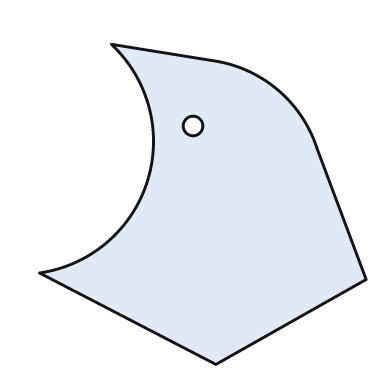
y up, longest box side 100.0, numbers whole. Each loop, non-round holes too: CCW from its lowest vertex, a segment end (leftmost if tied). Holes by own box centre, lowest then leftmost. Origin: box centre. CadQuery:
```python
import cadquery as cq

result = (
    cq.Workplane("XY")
    .moveTo(4.0, -49.0)
    .lineTo(50.0, -23.0)
    .lineTo(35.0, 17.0)
    .threePointArc((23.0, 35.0), (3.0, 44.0))
    .lineTo(-28.0, 49.0)
    .threePointArc((-17.0, 7.0), (-50.0, -21.0))
    .close()
    .moveTo(-3.0, 24.0)
    .circle(3.0)
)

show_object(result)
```